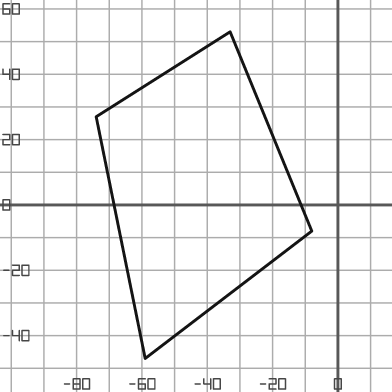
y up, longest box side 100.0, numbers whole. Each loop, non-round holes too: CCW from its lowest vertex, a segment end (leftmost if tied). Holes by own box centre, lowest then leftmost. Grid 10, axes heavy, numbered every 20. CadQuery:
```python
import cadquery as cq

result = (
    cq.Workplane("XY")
    .moveTo(-59.0, -47.0)
    .lineTo(-8.0, -8.0)
    .lineTo(-33.0, 53.0)
    .lineTo(-74.0, 27.0)
    .close()
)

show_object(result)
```